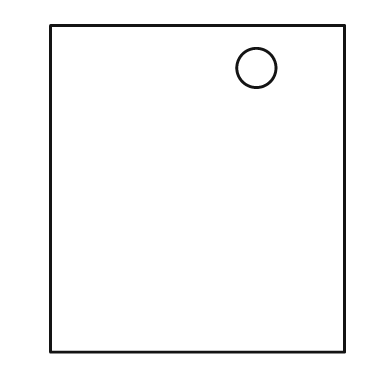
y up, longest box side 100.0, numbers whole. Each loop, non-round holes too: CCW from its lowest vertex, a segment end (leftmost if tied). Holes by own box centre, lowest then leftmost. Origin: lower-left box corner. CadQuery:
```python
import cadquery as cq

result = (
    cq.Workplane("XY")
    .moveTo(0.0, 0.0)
    .lineTo(90.0, 0.0)
    .lineTo(90.0, 100.0)
    .lineTo(0.0, 100.0)
    .close()
    .moveTo(63.0, 87.0)
    .circle(6.0)
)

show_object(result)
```